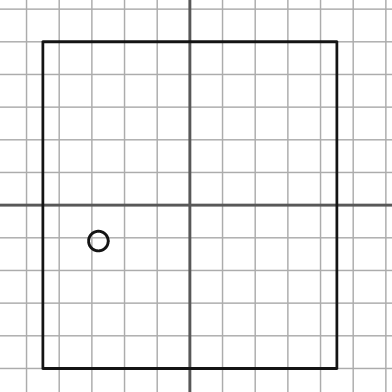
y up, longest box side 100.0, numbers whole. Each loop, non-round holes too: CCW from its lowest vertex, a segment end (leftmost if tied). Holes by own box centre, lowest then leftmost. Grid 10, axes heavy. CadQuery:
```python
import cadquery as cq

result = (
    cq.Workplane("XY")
    .moveTo(-45.0, -50.0)
    .lineTo(45.0, -50.0)
    .lineTo(45.0, 50.0)
    .lineTo(-45.0, 50.0)
    .close()
    .moveTo(-28.0, -11.0)
    .circle(3.0)
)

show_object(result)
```